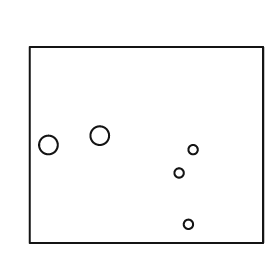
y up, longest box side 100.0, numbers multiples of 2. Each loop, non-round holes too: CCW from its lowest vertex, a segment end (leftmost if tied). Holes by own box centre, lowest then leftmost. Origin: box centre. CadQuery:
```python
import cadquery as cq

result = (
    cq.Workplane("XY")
    .moveTo(-50.0, -42.0)
    .lineTo(50.0, -42.0)
    .lineTo(50.0, 42.0)
    .lineTo(-50.0, 42.0)
    .close()
    .moveTo(18.0, -34.0)
    .circle(2.0)
    .moveTo(14.0, -12.0)
    .circle(2.0)
    .moveTo(20.0, -2.0)
    .circle(2.0)
    .moveTo(-42.0, 0.0)
    .circle(4.0)
    .moveTo(-20.0, 4.0)
    .circle(4.0)
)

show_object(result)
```